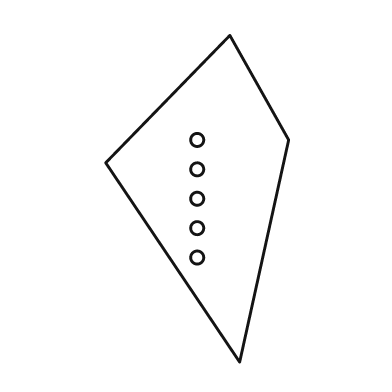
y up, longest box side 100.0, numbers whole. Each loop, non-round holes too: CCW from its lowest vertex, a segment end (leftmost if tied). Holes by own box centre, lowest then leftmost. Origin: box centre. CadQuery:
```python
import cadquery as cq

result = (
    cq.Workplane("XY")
    .moveTo(13.0, -50.0)
    .lineTo(28.0, 18.0)
    .lineTo(10.0, 50.0)
    .lineTo(-28.0, 11.0)
    .close()
    .moveTo(0.0, -18.0)
    .circle(2.0)
    .moveTo(0.0, -9.0)
    .circle(2.0)
    .moveTo(0.0, 0.0)
    .circle(2.0)
    .moveTo(0.0, 9.0)
    .circle(2.0)
    .moveTo(0.0, 18.0)
    .circle(2.0)
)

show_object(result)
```